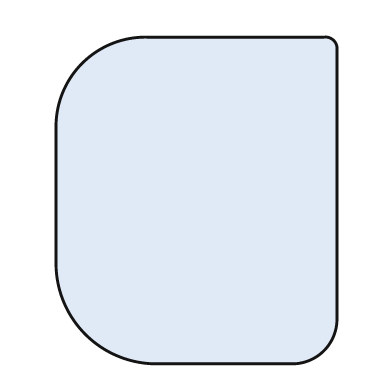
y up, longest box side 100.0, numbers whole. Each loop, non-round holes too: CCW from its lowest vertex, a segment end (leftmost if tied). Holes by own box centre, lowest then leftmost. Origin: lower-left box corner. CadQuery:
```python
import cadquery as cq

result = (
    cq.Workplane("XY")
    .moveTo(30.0, 0.0)
    .lineTo(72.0, 0.0)
    .threePointArc((82.0, 4.0), (86.0, 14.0))
    .lineTo(86.0, 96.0)
    .threePointArc((85.0, 99.0), (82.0, 100.0))
    .lineTo(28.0, 100.0)
    .threePointArc((8.0, 92.0), (0.0, 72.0))
    .lineTo(0.0, 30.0)
    .threePointArc((9.0, 9.0), (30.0, 0.0))
    .close()
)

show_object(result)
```